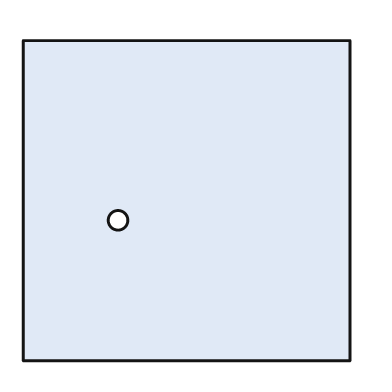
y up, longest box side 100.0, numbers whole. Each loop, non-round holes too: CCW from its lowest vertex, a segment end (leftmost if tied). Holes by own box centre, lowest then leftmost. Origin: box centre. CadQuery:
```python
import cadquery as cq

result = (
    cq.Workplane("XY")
    .moveTo(-50.0, -49.0)
    .lineTo(50.0, -49.0)
    .lineTo(50.0, 49.0)
    .lineTo(-50.0, 49.0)
    .close()
    .moveTo(-21.0, -6.0)
    .circle(3.0)
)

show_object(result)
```